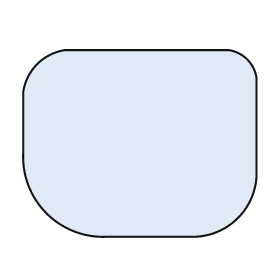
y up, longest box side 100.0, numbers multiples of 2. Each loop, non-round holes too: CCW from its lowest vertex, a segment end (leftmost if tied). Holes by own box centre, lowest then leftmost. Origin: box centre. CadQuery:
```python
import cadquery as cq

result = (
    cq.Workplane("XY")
    .moveTo(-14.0, -40.0)
    .lineTo(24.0, -40.0)
    .threePointArc((42.0, -32.0), (50.0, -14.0))
    .lineTo(50.0, 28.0)
    .threePointArc((46.0, 36.0), (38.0, 40.0))
    .lineTo(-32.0, 40.0)
    .threePointArc((-44.0, 34.0), (-50.0, 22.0))
    .lineTo(-50.0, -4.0)
    .threePointArc((-40.0, -30.0), (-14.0, -40.0))
    .close()
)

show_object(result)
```